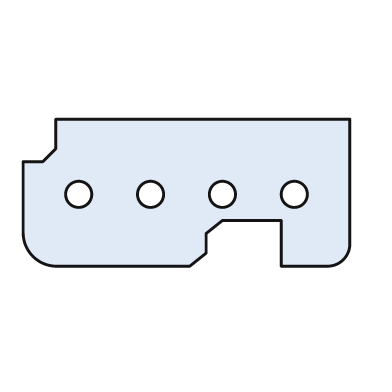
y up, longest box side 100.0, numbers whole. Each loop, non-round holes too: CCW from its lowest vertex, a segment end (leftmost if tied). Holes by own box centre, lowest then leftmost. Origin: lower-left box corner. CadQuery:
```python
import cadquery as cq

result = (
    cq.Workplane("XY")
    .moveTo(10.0, 0.0)
    .lineTo(51.0, 0.0)
    .lineTo(56.0, 4.0)
    .lineTo(56.0, 10.0)
    .lineTo(61.0, 14.0)
    .lineTo(79.0, 14.0)
    .lineTo(79.0, 0.0)
    .lineTo(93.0, 0.0)
    .threePointArc((98.0, 2.0), (100.0, 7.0))
    .lineTo(100.0, 45.0)
    .lineTo(10.0, 45.0)
    .lineTo(10.0, 36.0)
    .lineTo(6.0, 32.0)
    .lineTo(0.0, 32.0)
    .lineTo(0.0, 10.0)
    .threePointArc((3.0, 3.0), (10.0, 0.0))
    .close()
    .moveTo(17.0, 22.0)
    .circle(4.0)
    .moveTo(39.0, 22.0)
    .circle(4.0)
    .moveTo(61.0, 22.0)
    .circle(4.0)
    .moveTo(83.0, 22.0)
    .circle(4.0)
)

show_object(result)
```